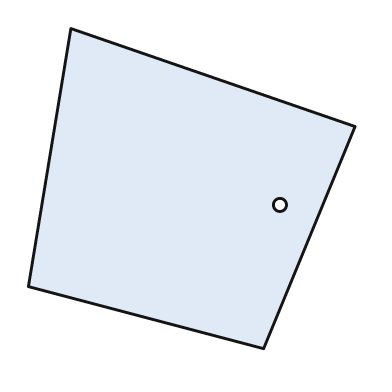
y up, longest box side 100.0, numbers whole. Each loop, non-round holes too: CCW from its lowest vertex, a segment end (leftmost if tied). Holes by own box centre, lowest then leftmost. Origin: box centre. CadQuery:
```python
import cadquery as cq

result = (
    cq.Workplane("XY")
    .moveTo(22.0, -49.0)
    .lineTo(50.0, 19.0)
    .lineTo(-37.0, 49.0)
    .lineTo(-50.0, -30.0)
    .close()
    .moveTo(27.0, -5.0)
    .circle(2.0)
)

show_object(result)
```